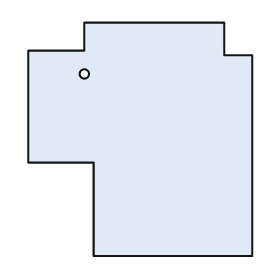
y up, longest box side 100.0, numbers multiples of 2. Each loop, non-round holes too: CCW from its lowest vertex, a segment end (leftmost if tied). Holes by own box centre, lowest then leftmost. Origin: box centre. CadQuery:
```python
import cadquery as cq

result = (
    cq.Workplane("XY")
    .moveTo(-20.0, -50.0)
    .lineTo(48.0, -50.0)
    .lineTo(48.0, 36.0)
    .lineTo(36.0, 36.0)
    .lineTo(36.0, 50.0)
    .lineTo(-24.0, 50.0)
    .lineTo(-24.0, 38.0)
    .lineTo(-48.0, 38.0)
    .lineTo(-48.0, -10.0)
    .lineTo(-20.0, -10.0)
    .close()
    .moveTo(-24.0, 28.0)
    .circle(2.0)
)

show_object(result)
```